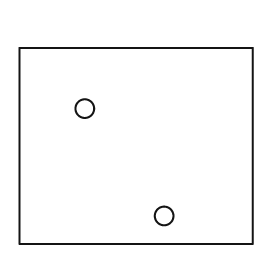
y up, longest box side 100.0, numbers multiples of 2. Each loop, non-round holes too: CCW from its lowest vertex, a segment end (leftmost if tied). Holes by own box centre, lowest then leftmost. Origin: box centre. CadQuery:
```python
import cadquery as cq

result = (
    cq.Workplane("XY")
    .moveTo(-50.0, -42.0)
    .lineTo(50.0, -42.0)
    .lineTo(50.0, 42.0)
    .lineTo(-50.0, 42.0)
    .close()
    .moveTo(12.0, -30.0)
    .circle(4.0)
    .moveTo(-22.0, 16.0)
    .circle(4.0)
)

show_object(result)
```